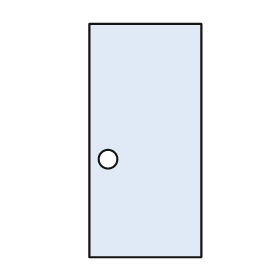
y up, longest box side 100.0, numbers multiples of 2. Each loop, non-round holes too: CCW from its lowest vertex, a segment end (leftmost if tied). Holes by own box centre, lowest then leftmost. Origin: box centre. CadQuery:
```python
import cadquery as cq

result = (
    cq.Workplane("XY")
    .moveTo(-24.0, -50.0)
    .lineTo(24.0, -50.0)
    .lineTo(24.0, 50.0)
    .lineTo(-24.0, 50.0)
    .close()
    .moveTo(-16.0, -8.0)
    .circle(4.0)
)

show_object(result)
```